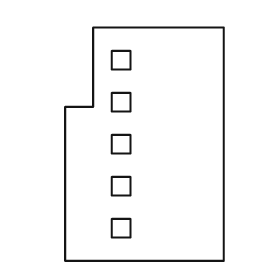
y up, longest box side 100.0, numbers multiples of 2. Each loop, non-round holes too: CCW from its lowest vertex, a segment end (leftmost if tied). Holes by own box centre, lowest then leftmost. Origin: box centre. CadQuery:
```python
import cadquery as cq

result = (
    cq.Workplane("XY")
    .moveTo(-34.0, -50.0)
    .lineTo(34.0, -50.0)
    .lineTo(34.0, 50.0)
    .lineTo(-22.0, 50.0)
    .lineTo(-22.0, 16.0)
    .lineTo(-34.0, 16.0)
    .close()
    .moveTo(-14.0, -40.0)
    .lineTo(-6.0, -40.0)
    .lineTo(-6.0, -32.0)
    .lineTo(-14.0, -32.0)
    .close()
    .moveTo(-14.0, -22.0)
    .lineTo(-6.0, -22.0)
    .lineTo(-6.0, -14.0)
    .lineTo(-14.0, -14.0)
    .close()
    .moveTo(-14.0, -4.0)
    .lineTo(-6.0, -4.0)
    .lineTo(-6.0, 4.0)
    .lineTo(-14.0, 4.0)
    .close()
    .moveTo(-14.0, 14.0)
    .lineTo(-6.0, 14.0)
    .lineTo(-6.0, 22.0)
    .lineTo(-14.0, 22.0)
    .close()
    .moveTo(-14.0, 32.0)
    .lineTo(-6.0, 32.0)
    .lineTo(-6.0, 40.0)
    .lineTo(-14.0, 40.0)
    .close()
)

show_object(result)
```